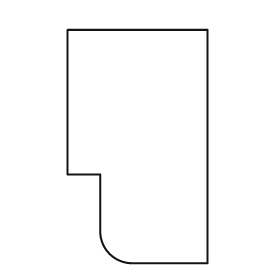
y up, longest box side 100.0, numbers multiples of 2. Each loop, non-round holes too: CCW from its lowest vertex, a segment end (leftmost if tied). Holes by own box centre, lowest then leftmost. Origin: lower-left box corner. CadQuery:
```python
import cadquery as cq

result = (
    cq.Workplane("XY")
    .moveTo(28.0, 0.0)
    .lineTo(60.0, 0.0)
    .lineTo(60.0, 100.0)
    .lineTo(0.0, 100.0)
    .lineTo(0.0, 38.0)
    .lineTo(14.0, 38.0)
    .lineTo(14.0, 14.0)
    .threePointArc((18.0, 4.0), (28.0, 0.0))
    .close()
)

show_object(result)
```